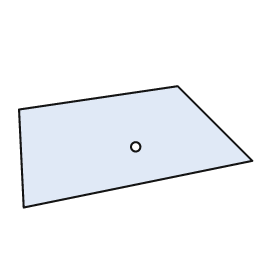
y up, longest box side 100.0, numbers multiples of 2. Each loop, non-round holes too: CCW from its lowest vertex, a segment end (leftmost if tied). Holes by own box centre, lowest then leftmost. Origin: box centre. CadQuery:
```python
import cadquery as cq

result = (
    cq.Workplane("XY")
    .moveTo(-48.0, -26.0)
    .lineTo(50.0, -6.0)
    .lineTo(18.0, 26.0)
    .lineTo(-50.0, 16.0)
    .close()
    .moveTo(0.0, 0.0)
    .circle(2.0)
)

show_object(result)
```